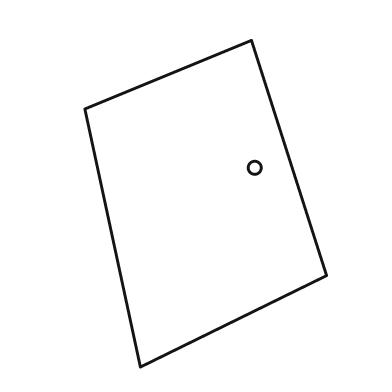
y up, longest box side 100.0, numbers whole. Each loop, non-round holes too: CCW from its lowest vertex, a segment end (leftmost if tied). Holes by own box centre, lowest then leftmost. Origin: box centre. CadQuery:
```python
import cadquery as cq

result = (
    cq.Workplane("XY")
    .moveTo(-20.0, -50.0)
    .lineTo(37.0, -22.0)
    .lineTo(14.0, 50.0)
    .lineTo(-37.0, 29.0)
    .close()
    .moveTo(15.0, 11.0)
    .circle(2.0)
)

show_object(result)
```